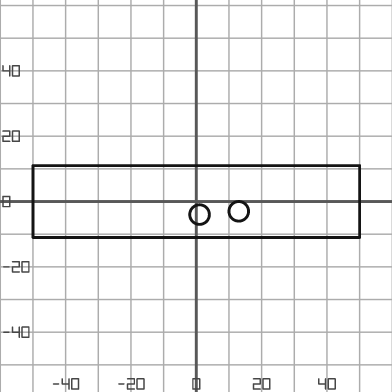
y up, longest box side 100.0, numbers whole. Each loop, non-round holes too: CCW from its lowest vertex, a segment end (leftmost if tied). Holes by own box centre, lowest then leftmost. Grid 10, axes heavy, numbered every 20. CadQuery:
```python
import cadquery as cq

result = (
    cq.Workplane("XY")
    .moveTo(-50.0, -11.0)
    .lineTo(50.0, -11.0)
    .lineTo(50.0, 11.0)
    .lineTo(-50.0, 11.0)
    .close()
    .moveTo(1.0, -4.0)
    .circle(3.0)
    .moveTo(13.0, -3.0)
    .circle(3.0)
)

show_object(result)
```